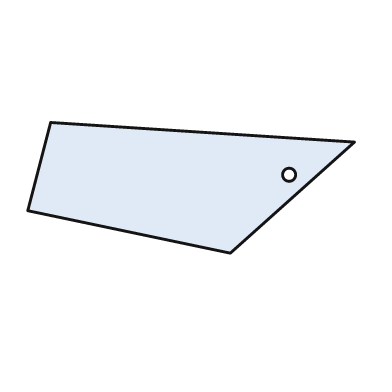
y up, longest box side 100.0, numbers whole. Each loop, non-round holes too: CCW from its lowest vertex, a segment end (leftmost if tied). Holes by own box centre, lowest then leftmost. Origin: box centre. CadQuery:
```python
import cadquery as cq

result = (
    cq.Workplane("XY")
    .moveTo(12.0, -20.0)
    .lineTo(50.0, 14.0)
    .lineTo(-43.0, 20.0)
    .lineTo(-50.0, -7.0)
    .close()
    .moveTo(30.0, 4.0)
    .circle(2.0)
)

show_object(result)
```